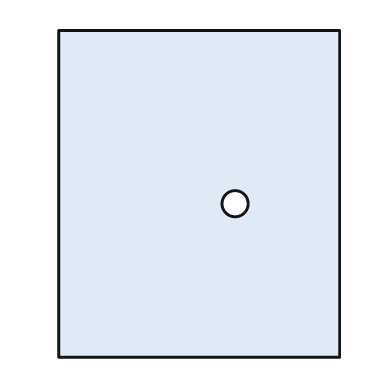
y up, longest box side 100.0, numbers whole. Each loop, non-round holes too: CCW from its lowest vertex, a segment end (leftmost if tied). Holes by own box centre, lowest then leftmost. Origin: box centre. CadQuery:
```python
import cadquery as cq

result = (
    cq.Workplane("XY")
    .moveTo(-43.0, -50.0)
    .lineTo(43.0, -50.0)
    .lineTo(43.0, 50.0)
    .lineTo(-43.0, 50.0)
    .close()
    .moveTo(11.0, -3.0)
    .circle(4.0)
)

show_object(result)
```